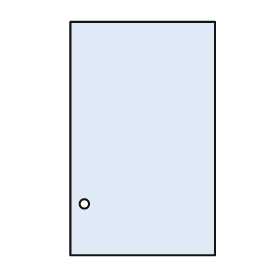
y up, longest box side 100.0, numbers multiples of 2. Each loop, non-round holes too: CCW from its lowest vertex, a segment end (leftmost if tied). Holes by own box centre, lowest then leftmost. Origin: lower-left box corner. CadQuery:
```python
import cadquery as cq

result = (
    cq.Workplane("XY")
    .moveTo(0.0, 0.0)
    .lineTo(62.0, 0.0)
    .lineTo(62.0, 100.0)
    .lineTo(0.0, 100.0)
    .close()
    .moveTo(6.0, 22.0)
    .circle(2.0)
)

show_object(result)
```